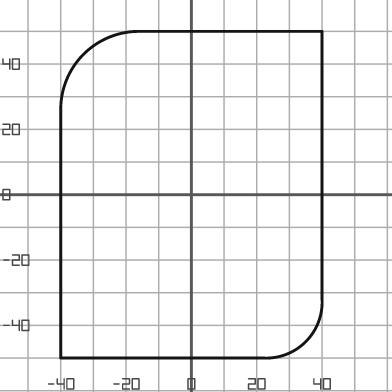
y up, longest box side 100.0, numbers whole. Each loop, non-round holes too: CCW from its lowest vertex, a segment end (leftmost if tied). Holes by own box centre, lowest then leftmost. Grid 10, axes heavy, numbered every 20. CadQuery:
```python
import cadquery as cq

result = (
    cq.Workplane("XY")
    .moveTo(-40.0, -50.0)
    .lineTo(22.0, -50.0)
    .threePointArc((35.0, -45.0), (40.0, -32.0))
    .lineTo(40.0, 50.0)
    .lineTo(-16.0, 50.0)
    .threePointArc((-33.0, 43.0), (-40.0, 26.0))
    .close()
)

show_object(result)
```